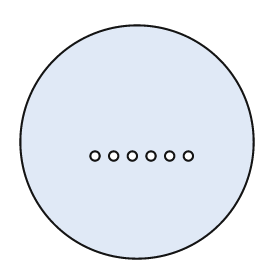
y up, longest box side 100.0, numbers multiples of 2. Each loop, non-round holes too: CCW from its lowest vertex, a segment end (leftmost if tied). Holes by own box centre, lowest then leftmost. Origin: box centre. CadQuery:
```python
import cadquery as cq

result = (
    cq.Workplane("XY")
    .moveTo(0.0, 0.0)
    .circle(50.0)
    .moveTo(-18.0, -6.0)
    .circle(2.0)
    .moveTo(-10.0, -6.0)
    .circle(2.0)
    .moveTo(-2.0, -6.0)
    .circle(2.0)
    .moveTo(6.0, -6.0)
    .circle(2.0)
    .moveTo(14.0, -6.0)
    .circle(2.0)
    .moveTo(22.0, -6.0)
    .circle(2.0)
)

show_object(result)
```